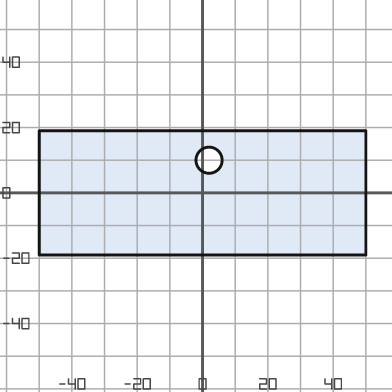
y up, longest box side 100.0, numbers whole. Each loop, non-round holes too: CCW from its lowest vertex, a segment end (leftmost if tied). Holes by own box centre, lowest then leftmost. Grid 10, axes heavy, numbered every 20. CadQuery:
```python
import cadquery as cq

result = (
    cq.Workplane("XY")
    .moveTo(-50.0, -19.0)
    .lineTo(50.0, -19.0)
    .lineTo(50.0, 19.0)
    .lineTo(-50.0, 19.0)
    .close()
    .moveTo(2.0, 10.0)
    .circle(4.0)
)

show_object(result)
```